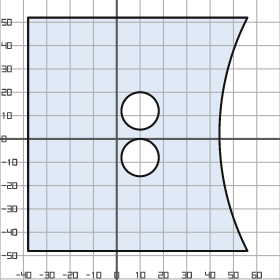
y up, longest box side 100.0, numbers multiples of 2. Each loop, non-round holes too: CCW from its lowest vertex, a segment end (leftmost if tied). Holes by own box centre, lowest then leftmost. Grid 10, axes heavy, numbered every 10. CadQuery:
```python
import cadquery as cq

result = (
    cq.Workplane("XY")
    .moveTo(-38.0, -48.0)
    .lineTo(56.0, -48.0)
    .threePointArc((44.0, 2.0), (56.0, 52.0))
    .lineTo(-38.0, 52.0)
    .close()
    .moveTo(10.0, -8.0)
    .circle(8.0)
    .moveTo(10.0, 12.0)
    .circle(8.0)
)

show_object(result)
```